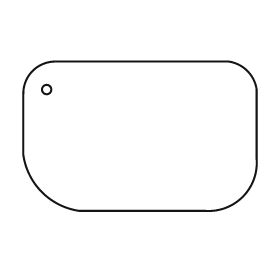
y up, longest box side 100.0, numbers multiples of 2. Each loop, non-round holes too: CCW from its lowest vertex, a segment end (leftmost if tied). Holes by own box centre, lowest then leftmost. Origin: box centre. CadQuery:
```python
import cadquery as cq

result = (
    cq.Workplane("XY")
    .moveTo(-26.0, -32.0)
    .lineTo(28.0, -32.0)
    .threePointArc((44.0, -26.0), (50.0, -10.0))
    .lineTo(50.0, 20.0)
    .threePointArc((46.0, 28.0), (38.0, 32.0))
    .lineTo(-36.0, 32.0)
    .threePointArc((-46.0, 28.0), (-50.0, 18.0))
    .lineTo(-50.0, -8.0)
    .threePointArc((-42.0, -24.0), (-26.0, -32.0))
    .close()
    .moveTo(-40.0, 20.0)
    .circle(2.0)
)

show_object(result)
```